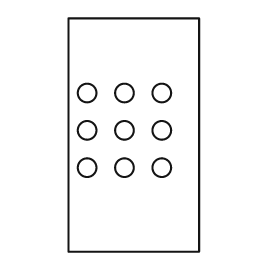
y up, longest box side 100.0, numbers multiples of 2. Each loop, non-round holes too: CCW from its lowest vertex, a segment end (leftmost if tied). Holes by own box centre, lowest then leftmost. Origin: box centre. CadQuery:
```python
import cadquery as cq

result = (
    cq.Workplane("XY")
    .moveTo(-28.0, -50.0)
    .lineTo(28.0, -50.0)
    .lineTo(28.0, 50.0)
    .lineTo(-28.0, 50.0)
    .close()
    .moveTo(-20.0, -14.0)
    .circle(4.0)
    .moveTo(-4.0, -14.0)
    .circle(4.0)
    .moveTo(12.0, -14.0)
    .circle(4.0)
    .moveTo(-20.0, 2.0)
    .circle(4.0)
    .moveTo(-4.0, 2.0)
    .circle(4.0)
    .moveTo(12.0, 2.0)
    .circle(4.0)
    .moveTo(-20.0, 18.0)
    .circle(4.0)
    .moveTo(-4.0, 18.0)
    .circle(4.0)
    .moveTo(12.0, 18.0)
    .circle(4.0)
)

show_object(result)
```